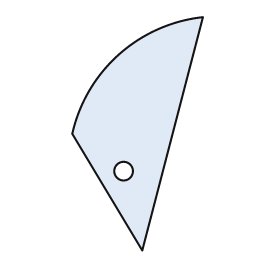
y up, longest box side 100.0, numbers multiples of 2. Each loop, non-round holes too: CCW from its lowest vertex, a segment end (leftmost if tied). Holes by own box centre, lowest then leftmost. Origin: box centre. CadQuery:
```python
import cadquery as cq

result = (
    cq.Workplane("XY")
    .moveTo(2.0, -50.0)
    .lineTo(28.0, 50.0)
    .threePointArc((-8.0, 34.0), (-28.0, 0.0))
    .close()
    .moveTo(-6.0, -16.0)
    .circle(4.0)
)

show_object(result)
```